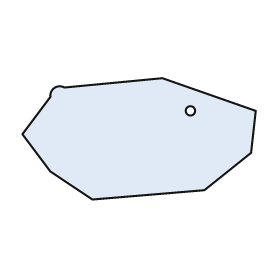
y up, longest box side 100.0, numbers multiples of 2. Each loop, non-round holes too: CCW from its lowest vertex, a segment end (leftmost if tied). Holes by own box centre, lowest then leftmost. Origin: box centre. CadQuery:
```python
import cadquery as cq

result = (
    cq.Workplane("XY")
    .moveTo(-20.0, -26.0)
    .lineTo(28.0, -22.0)
    .lineTo(48.0, -6.0)
    .lineTo(50.0, 12.0)
    .lineTo(10.0, 26.0)
    .lineTo(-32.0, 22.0)
    .threePointArc((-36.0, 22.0), (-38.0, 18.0))
    .lineTo(-50.0, 2.0)
    .lineTo(-38.0, -14.0)
    .close()
    .moveTo(22.0, 12.0)
    .circle(2.0)
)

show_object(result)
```